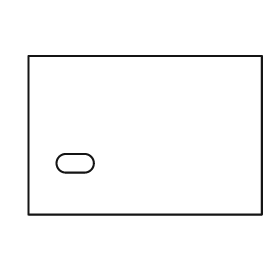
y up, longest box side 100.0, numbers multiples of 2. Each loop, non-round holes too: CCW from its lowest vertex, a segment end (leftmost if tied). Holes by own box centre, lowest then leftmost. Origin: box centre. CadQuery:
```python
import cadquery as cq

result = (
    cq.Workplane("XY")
    .moveTo(-50.0, -34.0)
    .lineTo(50.0, -34.0)
    .lineTo(50.0, 34.0)
    .lineTo(-50.0, 34.0)
    .close()
    .moveTo(-34.0, -16.0)
    .lineTo(-26.0, -16.0)
    .threePointArc((-22.0, -12.0), (-26.0, -8.0))
    .lineTo(-34.0, -8.0)
    .threePointArc((-38.0, -12.0), (-34.0, -16.0))
    .close()
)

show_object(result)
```